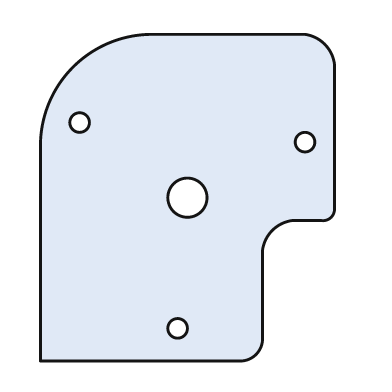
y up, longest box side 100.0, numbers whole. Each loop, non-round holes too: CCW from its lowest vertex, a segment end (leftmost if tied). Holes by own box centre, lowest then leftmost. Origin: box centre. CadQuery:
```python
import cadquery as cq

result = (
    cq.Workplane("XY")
    .moveTo(-45.0, -50.0)
    .lineTo(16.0, -50.0)
    .threePointArc((21.0, -48.0), (23.0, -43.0))
    .lineTo(23.0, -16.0)
    .threePointArc((26.0, -10.0), (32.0, -7.0))
    .lineTo(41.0, -7.0)
    .threePointArc((44.0, -6.0), (45.0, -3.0))
    .lineTo(45.0, 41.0)
    .threePointArc((42.0, 47.0), (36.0, 50.0))
    .lineTo(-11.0, 50.0)
    .threePointArc((-35.0, 40.0), (-45.0, 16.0))
    .close()
    .moveTo(-3.0, -40.0)
    .circle(3.0)
    .moveTo(0.0, 0.0)
    .circle(6.0)
    .moveTo(36.0, 17.0)
    .circle(3.0)
    .moveTo(-33.0, 23.0)
    .circle(3.0)
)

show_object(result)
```